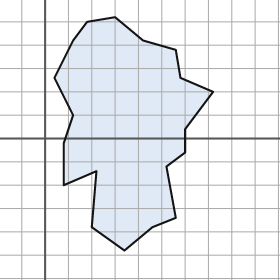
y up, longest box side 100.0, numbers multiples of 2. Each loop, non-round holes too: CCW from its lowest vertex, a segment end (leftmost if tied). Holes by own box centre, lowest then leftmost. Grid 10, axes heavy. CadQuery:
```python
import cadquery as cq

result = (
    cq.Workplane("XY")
    .moveTo(34.0, -48.0)
    .lineTo(46.0, -38.0)
    .lineTo(56.0, -34.0)
    .lineTo(52.0, -12.0)
    .lineTo(60.0, -6.0)
    .lineTo(60.0, 4.0)
    .lineTo(72.0, 20.0)
    .lineTo(58.0, 26.0)
    .lineTo(56.0, 38.0)
    .lineTo(42.0, 42.0)
    .lineTo(30.0, 52.0)
    .lineTo(18.0, 50.0)
    .lineTo(12.0, 42.0)
    .lineTo(4.0, 26.0)
    .lineTo(12.0, 10.0)
    .lineTo(8.0, -2.0)
    .lineTo(8.0, -20.0)
    .lineTo(22.0, -14.0)
    .lineTo(20.0, -38.0)
    .close()
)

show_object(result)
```